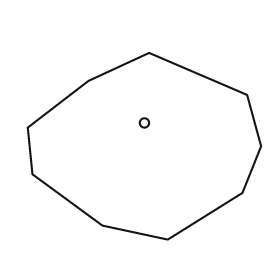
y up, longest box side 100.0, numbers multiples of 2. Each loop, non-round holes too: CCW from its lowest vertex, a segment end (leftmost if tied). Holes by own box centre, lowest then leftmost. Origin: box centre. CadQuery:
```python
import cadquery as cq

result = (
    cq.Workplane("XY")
    .moveTo(10.0, -40.0)
    .lineTo(42.0, -20.0)
    .lineTo(50.0, 0.0)
    .lineTo(44.0, 22.0)
    .lineTo(2.0, 40.0)
    .lineTo(-24.0, 28.0)
    .lineTo(-50.0, 8.0)
    .lineTo(-48.0, -12.0)
    .lineTo(-18.0, -34.0)
    .close()
    .moveTo(0.0, 10.0)
    .circle(2.0)
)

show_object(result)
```